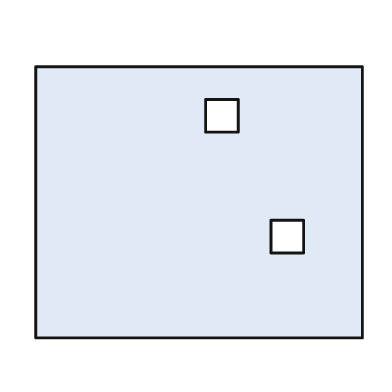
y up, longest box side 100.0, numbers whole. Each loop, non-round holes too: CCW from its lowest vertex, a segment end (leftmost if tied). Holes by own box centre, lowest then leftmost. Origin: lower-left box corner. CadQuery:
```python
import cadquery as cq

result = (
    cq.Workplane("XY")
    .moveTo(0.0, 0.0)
    .lineTo(100.0, 0.0)
    .lineTo(100.0, 83.0)
    .lineTo(0.0, 83.0)
    .close()
    .moveTo(72.0, 26.0)
    .lineTo(82.0, 26.0)
    .lineTo(82.0, 36.0)
    .lineTo(72.0, 36.0)
    .close()
    .moveTo(52.0, 63.0)
    .lineTo(62.0, 63.0)
    .lineTo(62.0, 73.0)
    .lineTo(52.0, 73.0)
    .close()
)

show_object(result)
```